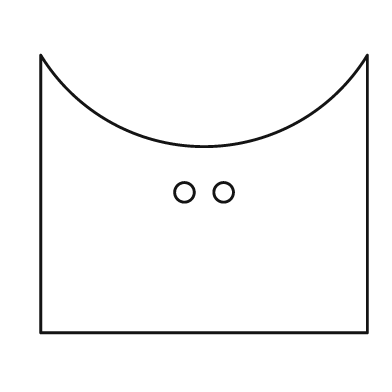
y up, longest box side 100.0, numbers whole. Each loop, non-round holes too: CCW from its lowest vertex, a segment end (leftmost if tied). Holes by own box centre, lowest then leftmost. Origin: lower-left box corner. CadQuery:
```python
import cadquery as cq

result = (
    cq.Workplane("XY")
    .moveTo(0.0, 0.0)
    .lineTo(100.0, 0.0)
    .lineTo(100.0, 85.0)
    .threePointArc((50.0, 57.0), (0.0, 85.0))
    .close()
    .moveTo(44.0, 43.0)
    .circle(3.0)
    .moveTo(56.0, 43.0)
    .circle(3.0)
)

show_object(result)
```